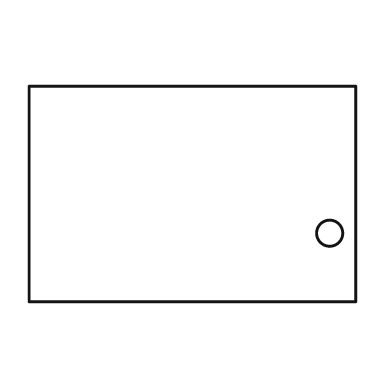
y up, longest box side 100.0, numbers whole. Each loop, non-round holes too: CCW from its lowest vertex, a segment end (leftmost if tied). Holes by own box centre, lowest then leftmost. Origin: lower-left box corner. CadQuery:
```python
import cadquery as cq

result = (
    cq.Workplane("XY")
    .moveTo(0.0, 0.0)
    .lineTo(100.0, 0.0)
    .lineTo(100.0, 66.0)
    .lineTo(0.0, 66.0)
    .close()
    .moveTo(92.0, 21.0)
    .circle(4.0)
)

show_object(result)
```